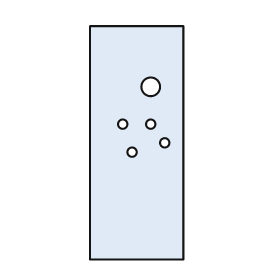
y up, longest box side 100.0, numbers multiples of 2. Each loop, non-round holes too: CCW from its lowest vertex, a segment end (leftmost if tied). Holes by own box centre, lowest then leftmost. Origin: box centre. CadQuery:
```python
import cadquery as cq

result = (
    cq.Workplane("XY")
    .moveTo(-20.0, -50.0)
    .lineTo(20.0, -50.0)
    .lineTo(20.0, 50.0)
    .lineTo(-20.0, 50.0)
    .close()
    .moveTo(-2.0, -4.0)
    .circle(2.0)
    .moveTo(12.0, 0.0)
    .circle(2.0)
    .moveTo(-6.0, 8.0)
    .circle(2.0)
    .moveTo(6.0, 8.0)
    .circle(2.0)
    .moveTo(6.0, 24.0)
    .circle(4.0)
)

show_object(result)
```